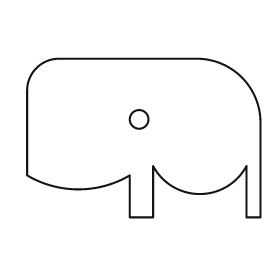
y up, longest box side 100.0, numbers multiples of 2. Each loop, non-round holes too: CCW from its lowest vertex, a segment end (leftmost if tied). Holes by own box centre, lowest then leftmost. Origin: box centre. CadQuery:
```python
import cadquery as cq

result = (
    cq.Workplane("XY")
    .moveTo(-6.0, -34.0)
    .lineTo(4.0, -34.0)
    .lineTo(4.0, -12.0)
    .threePointArc((24.0, -24.0), (44.0, -12.0))
    .lineTo(44.0, -34.0)
    .lineTo(50.0, -34.0)
    .lineTo(50.0, 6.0)
    .threePointArc((42.0, 26.0), (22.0, 34.0))
    .lineTo(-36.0, 34.0)
    .threePointArc((-46.0, 30.0), (-50.0, 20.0))
    .lineTo(-50.0, -16.0)
    .threePointArc((-28.0, -22.0), (-6.0, -16.0))
    .close()
    .moveTo(-2.0, 8.0)
    .circle(4.0)
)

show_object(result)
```